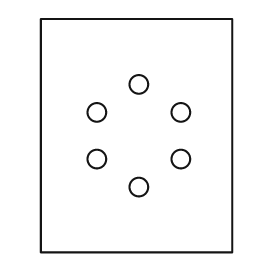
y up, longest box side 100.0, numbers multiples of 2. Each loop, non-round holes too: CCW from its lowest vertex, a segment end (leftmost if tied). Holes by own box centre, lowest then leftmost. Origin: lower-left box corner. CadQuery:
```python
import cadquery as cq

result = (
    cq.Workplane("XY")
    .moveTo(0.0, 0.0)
    .lineTo(82.0, 0.0)
    .lineTo(82.0, 100.0)
    .lineTo(0.0, 100.0)
    .close()
    .moveTo(42.0, 28.0)
    .circle(4.0)
    .moveTo(24.0, 40.0)
    .circle(4.0)
    .moveTo(60.0, 40.0)
    .circle(4.0)
    .moveTo(24.0, 60.0)
    .circle(4.0)
    .moveTo(60.0, 60.0)
    .circle(4.0)
    .moveTo(42.0, 72.0)
    .circle(4.0)
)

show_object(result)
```